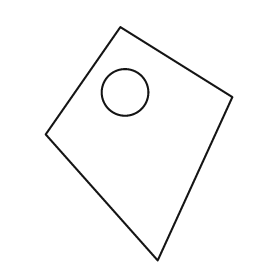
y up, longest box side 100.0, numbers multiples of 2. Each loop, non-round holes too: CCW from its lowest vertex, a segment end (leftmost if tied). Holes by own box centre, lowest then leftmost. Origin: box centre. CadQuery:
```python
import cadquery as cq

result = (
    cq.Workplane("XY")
    .moveTo(8.0, -50.0)
    .lineTo(40.0, 20.0)
    .lineTo(-8.0, 50.0)
    .lineTo(-40.0, 4.0)
    .close()
    .moveTo(-6.0, 22.0)
    .circle(10.0)
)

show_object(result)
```